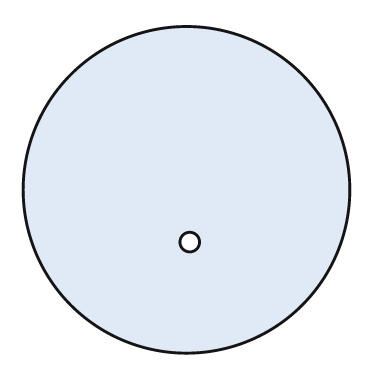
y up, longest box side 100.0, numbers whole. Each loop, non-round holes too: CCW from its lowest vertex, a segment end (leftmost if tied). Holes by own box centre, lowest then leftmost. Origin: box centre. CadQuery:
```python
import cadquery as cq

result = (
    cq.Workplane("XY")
    .moveTo(0.0, 0.0)
    .circle(50.0)
    .moveTo(1.0, -16.0)
    .circle(3.0)
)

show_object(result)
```